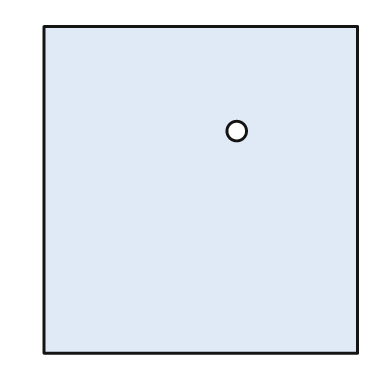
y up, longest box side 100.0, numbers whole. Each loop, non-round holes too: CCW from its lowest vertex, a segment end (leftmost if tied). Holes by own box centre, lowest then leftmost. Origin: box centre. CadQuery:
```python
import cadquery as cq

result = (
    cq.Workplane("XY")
    .moveTo(-48.0, -50.0)
    .lineTo(48.0, -50.0)
    .lineTo(48.0, 50.0)
    .lineTo(-48.0, 50.0)
    .close()
    .moveTo(11.0, 18.0)
    .circle(3.0)
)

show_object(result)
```